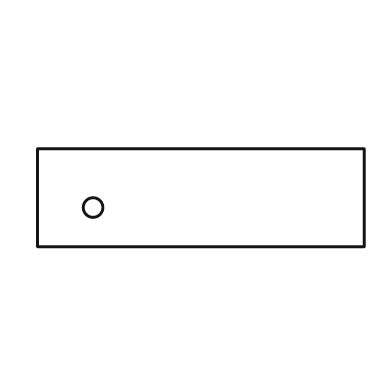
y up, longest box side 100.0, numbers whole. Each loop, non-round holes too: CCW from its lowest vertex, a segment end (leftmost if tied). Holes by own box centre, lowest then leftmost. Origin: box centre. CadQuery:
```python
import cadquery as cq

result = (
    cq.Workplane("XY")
    .moveTo(-50.0, -15.0)
    .lineTo(50.0, -15.0)
    .lineTo(50.0, 15.0)
    .lineTo(-50.0, 15.0)
    .close()
    .moveTo(-33.0, -3.0)
    .circle(3.0)
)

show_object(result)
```